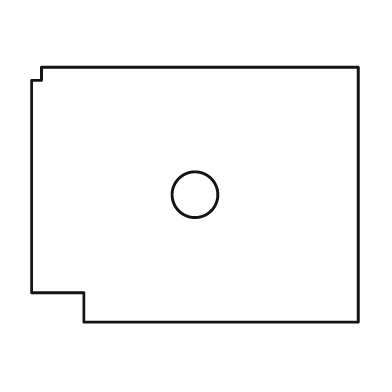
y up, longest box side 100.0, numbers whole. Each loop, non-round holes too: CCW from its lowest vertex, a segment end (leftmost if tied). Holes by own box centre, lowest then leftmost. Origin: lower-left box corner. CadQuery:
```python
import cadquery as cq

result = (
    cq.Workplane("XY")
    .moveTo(16.0, 0.0)
    .lineTo(100.0, 0.0)
    .lineTo(100.0, 78.0)
    .lineTo(3.0, 78.0)
    .lineTo(3.0, 74.0)
    .lineTo(0.0, 74.0)
    .lineTo(0.0, 9.0)
    .lineTo(16.0, 9.0)
    .close()
    .moveTo(50.0, 39.0)
    .circle(7.0)
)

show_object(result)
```